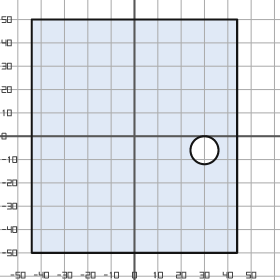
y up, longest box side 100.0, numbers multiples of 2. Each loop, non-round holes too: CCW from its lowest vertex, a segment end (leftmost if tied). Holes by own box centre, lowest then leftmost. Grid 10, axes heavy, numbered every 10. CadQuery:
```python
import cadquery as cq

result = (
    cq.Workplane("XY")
    .moveTo(-44.0, -50.0)
    .lineTo(44.0, -50.0)
    .lineTo(44.0, 50.0)
    .lineTo(-44.0, 50.0)
    .close()
    .moveTo(30.0, -6.0)
    .circle(6.0)
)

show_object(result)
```